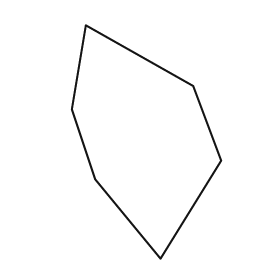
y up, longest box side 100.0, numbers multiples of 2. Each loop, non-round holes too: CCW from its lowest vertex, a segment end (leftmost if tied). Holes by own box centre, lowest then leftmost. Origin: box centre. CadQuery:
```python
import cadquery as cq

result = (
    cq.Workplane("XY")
    .moveTo(6.0, -50.0)
    .lineTo(32.0, -8.0)
    .lineTo(20.0, 24.0)
    .lineTo(-26.0, 50.0)
    .lineTo(-32.0, 14.0)
    .lineTo(-22.0, -16.0)
    .close()
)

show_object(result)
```